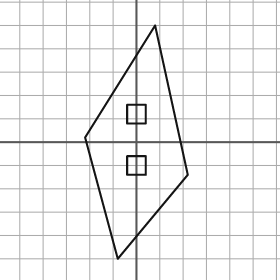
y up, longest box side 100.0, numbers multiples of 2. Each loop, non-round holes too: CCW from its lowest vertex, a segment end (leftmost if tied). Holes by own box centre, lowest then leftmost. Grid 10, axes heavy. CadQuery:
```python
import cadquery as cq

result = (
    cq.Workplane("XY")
    .moveTo(-8.0, -50.0)
    .lineTo(22.0, -14.0)
    .lineTo(8.0, 50.0)
    .lineTo(-22.0, 2.0)
    .close()
    .moveTo(-4.0, -14.0)
    .lineTo(4.0, -14.0)
    .lineTo(4.0, -6.0)
    .lineTo(-4.0, -6.0)
    .close()
    .moveTo(-4.0, 8.0)
    .lineTo(4.0, 8.0)
    .lineTo(4.0, 16.0)
    .lineTo(-4.0, 16.0)
    .close()
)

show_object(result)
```